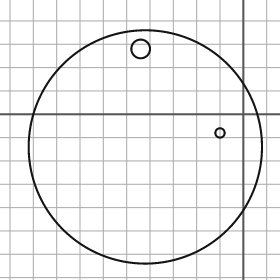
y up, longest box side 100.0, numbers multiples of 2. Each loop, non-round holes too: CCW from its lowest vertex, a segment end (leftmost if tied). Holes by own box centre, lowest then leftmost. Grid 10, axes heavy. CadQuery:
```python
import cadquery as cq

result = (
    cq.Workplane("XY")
    .moveTo(-42.0, -14.0)
    .circle(50.0)
    .moveTo(-10.0, -8.0)
    .circle(2.0)
    .moveTo(-44.0, 28.0)
    .circle(4.0)
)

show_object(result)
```